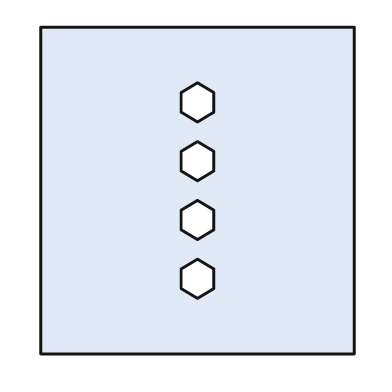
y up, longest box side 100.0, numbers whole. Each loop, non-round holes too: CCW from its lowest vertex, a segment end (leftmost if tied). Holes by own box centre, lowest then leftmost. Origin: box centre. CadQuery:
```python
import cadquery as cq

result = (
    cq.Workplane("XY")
    .moveTo(-48.0, -50.0)
    .lineTo(48.0, -50.0)
    .lineTo(48.0, 50.0)
    .lineTo(-48.0, 50.0)
    .close()
    .moveTo(0.0, -33.0)
    .lineTo(5.0, -30.0)
    .lineTo(5.0, -24.0)
    .lineTo(0.0, -21.0)
    .lineTo(-5.0, -24.0)
    .lineTo(-5.0, -30.0)
    .close()
    .moveTo(0.0, -15.0)
    .lineTo(5.0, -12.0)
    .lineTo(5.0, -6.0)
    .lineTo(0.0, -3.0)
    .lineTo(-5.0, -6.0)
    .lineTo(-5.0, -12.0)
    .close()
    .moveTo(0.0, 3.0)
    .lineTo(5.0, 6.0)
    .lineTo(5.0, 12.0)
    .lineTo(0.0, 15.0)
    .lineTo(-5.0, 12.0)
    .lineTo(-5.0, 6.0)
    .close()
    .moveTo(0.0, 21.0)
    .lineTo(5.0, 24.0)
    .lineTo(5.0, 30.0)
    .lineTo(0.0, 33.0)
    .lineTo(-5.0, 30.0)
    .lineTo(-5.0, 24.0)
    .close()
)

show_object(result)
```